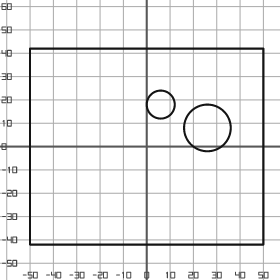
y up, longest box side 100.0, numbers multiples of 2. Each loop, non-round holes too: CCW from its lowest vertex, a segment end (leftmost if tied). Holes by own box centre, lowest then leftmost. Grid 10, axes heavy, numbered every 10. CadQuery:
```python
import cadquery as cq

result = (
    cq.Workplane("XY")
    .moveTo(-50.0, -42.0)
    .lineTo(50.0, -42.0)
    .lineTo(50.0, 42.0)
    .lineTo(-50.0, 42.0)
    .close()
    .moveTo(26.0, 8.0)
    .circle(10.0)
    .moveTo(6.0, 18.0)
    .circle(6.0)
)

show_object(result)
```